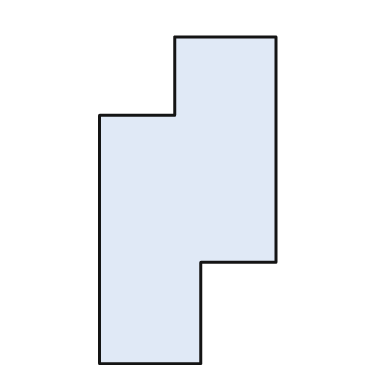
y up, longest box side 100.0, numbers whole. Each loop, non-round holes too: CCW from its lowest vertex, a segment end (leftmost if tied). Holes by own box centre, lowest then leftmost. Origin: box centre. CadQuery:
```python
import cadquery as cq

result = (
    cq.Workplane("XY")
    .moveTo(-27.0, -50.0)
    .lineTo(4.0, -50.0)
    .lineTo(4.0, -19.0)
    .lineTo(27.0, -19.0)
    .lineTo(27.0, 50.0)
    .lineTo(-4.0, 50.0)
    .lineTo(-4.0, 26.0)
    .lineTo(-27.0, 26.0)
    .close()
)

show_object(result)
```